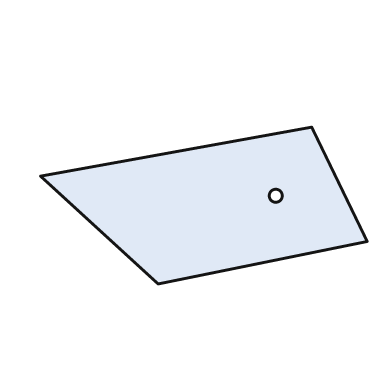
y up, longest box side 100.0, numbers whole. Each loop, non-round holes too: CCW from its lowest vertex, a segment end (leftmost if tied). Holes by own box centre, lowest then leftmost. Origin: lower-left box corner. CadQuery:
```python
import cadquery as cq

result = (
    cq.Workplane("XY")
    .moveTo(36.0, 0.0)
    .lineTo(100.0, 13.0)
    .lineTo(83.0, 48.0)
    .lineTo(0.0, 33.0)
    .close()
    .moveTo(72.0, 27.0)
    .circle(2.0)
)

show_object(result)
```